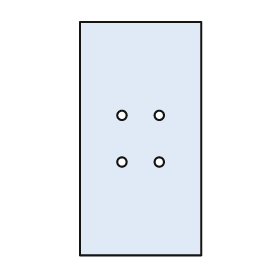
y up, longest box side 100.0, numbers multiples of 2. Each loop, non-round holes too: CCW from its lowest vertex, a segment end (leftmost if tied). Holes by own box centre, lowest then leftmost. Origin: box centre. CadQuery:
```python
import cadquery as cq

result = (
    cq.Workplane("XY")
    .moveTo(-26.0, -50.0)
    .lineTo(26.0, -50.0)
    .lineTo(26.0, 50.0)
    .lineTo(-26.0, 50.0)
    .close()
    .moveTo(-8.0, -10.0)
    .circle(2.0)
    .moveTo(8.0, -10.0)
    .circle(2.0)
    .moveTo(-8.0, 10.0)
    .circle(2.0)
    .moveTo(8.0, 10.0)
    .circle(2.0)
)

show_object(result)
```